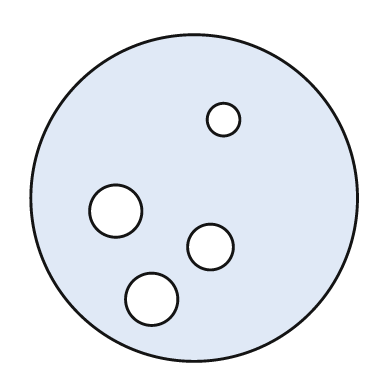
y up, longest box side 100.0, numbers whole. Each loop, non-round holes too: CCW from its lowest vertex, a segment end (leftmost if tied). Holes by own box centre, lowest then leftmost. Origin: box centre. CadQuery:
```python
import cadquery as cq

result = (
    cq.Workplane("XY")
    .moveTo(0.0, 0.0)
    .circle(50.0)
    .moveTo(-13.0, -31.0)
    .circle(8.0)
    .moveTo(5.0, -15.0)
    .circle(7.0)
    .moveTo(-24.0, -4.0)
    .circle(8.0)
    .moveTo(9.0, 24.0)
    .circle(5.0)
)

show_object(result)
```